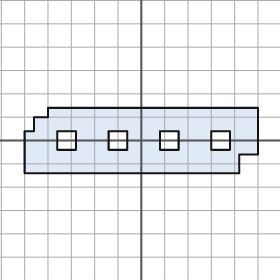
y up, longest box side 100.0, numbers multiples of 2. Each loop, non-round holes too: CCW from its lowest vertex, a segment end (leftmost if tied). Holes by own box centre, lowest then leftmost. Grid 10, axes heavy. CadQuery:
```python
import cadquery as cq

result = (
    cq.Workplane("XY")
    .moveTo(-50.0, -14.0)
    .lineTo(42.0, -14.0)
    .lineTo(42.0, -6.0)
    .lineTo(50.0, -6.0)
    .lineTo(50.0, 14.0)
    .lineTo(-40.0, 14.0)
    .lineTo(-40.0, 10.0)
    .lineTo(-46.0, 10.0)
    .lineTo(-46.0, 4.0)
    .lineTo(-50.0, 4.0)
    .close()
    .moveTo(-36.0, -4.0)
    .lineTo(-28.0, -4.0)
    .lineTo(-28.0, 4.0)
    .lineTo(-36.0, 4.0)
    .close()
    .moveTo(-14.0, -4.0)
    .lineTo(-6.0, -4.0)
    .lineTo(-6.0, 4.0)
    .lineTo(-14.0, 4.0)
    .close()
    .moveTo(8.0, -4.0)
    .lineTo(16.0, -4.0)
    .lineTo(16.0, 4.0)
    .lineTo(8.0, 4.0)
    .close()
    .moveTo(30.0, -4.0)
    .lineTo(38.0, -4.0)
    .lineTo(38.0, 4.0)
    .lineTo(30.0, 4.0)
    .close()
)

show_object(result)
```